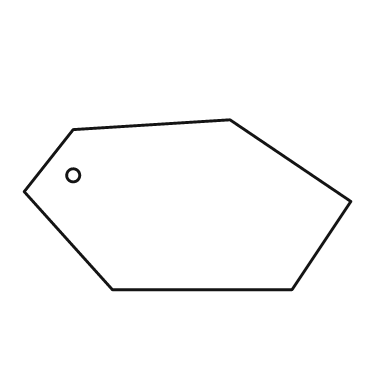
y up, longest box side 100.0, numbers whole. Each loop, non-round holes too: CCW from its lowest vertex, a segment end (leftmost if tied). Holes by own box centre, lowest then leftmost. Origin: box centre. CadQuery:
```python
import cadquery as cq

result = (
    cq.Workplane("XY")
    .moveTo(-23.0, -26.0)
    .lineTo(32.0, -26.0)
    .lineTo(50.0, 1.0)
    .lineTo(13.0, 26.0)
    .lineTo(-35.0, 23.0)
    .lineTo(-50.0, 4.0)
    .close()
    .moveTo(-35.0, 9.0)
    .circle(2.0)
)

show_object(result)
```